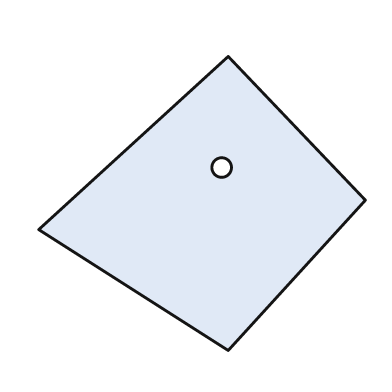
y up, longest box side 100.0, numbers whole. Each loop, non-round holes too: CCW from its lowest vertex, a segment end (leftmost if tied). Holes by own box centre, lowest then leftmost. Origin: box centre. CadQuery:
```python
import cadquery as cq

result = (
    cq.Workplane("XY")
    .moveTo(8.0, -45.0)
    .lineTo(50.0, 1.0)
    .lineTo(8.0, 45.0)
    .lineTo(-50.0, -8.0)
    .close()
    .moveTo(6.0, 11.0)
    .circle(3.0)
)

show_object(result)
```